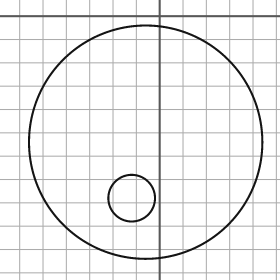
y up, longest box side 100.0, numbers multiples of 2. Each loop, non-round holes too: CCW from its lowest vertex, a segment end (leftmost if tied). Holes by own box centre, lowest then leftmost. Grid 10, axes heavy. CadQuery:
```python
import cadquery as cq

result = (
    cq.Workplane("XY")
    .moveTo(-6.0, -54.0)
    .circle(50.0)
    .moveTo(-12.0, -78.0)
    .circle(10.0)
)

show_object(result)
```